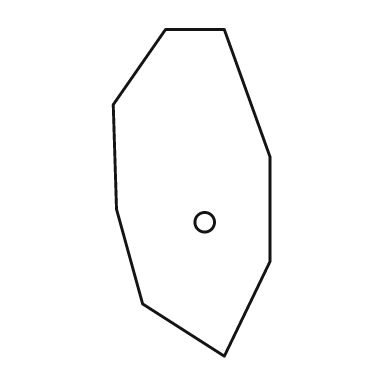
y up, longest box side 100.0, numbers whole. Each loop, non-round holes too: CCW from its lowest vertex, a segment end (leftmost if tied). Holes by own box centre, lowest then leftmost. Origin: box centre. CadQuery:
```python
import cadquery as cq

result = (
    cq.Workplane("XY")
    .moveTo(10.0, -50.0)
    .lineTo(24.0, -21.0)
    .lineTo(24.0, 11.0)
    .lineTo(10.0, 50.0)
    .lineTo(-8.0, 50.0)
    .lineTo(-24.0, 27.0)
    .lineTo(-23.0, -5.0)
    .lineTo(-15.0, -34.0)
    .close()
    .moveTo(4.0, -9.0)
    .circle(3.0)
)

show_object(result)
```